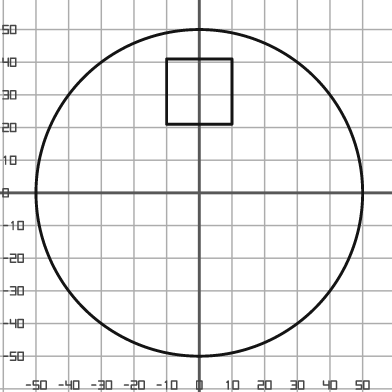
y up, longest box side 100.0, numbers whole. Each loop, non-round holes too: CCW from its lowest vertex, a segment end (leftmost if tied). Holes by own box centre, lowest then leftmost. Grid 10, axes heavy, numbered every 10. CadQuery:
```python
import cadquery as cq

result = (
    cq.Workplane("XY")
    .moveTo(0.0, 0.0)
    .circle(50.0)
    .moveTo(-10.0, 21.0)
    .lineTo(10.0, 21.0)
    .lineTo(10.0, 41.0)
    .lineTo(-10.0, 41.0)
    .close()
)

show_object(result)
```